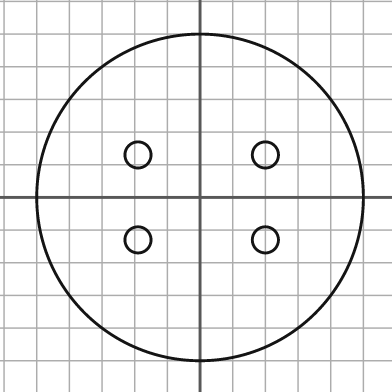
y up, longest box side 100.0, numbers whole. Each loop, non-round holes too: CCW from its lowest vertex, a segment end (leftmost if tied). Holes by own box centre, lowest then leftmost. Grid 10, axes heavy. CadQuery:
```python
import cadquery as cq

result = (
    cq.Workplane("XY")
    .moveTo(0.0, 0.0)
    .circle(50.0)
    .moveTo(-19.0, -13.0)
    .circle(4.0)
    .moveTo(20.0, -13.0)
    .circle(4.0)
    .moveTo(-19.0, 13.0)
    .circle(4.0)
    .moveTo(20.0, 13.0)
    .circle(4.0)
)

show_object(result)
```